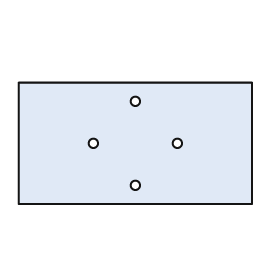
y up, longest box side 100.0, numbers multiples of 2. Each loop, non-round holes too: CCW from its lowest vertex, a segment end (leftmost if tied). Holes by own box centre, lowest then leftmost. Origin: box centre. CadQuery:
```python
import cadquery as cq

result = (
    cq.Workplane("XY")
    .moveTo(-50.0, -26.0)
    .lineTo(50.0, -26.0)
    .lineTo(50.0, 26.0)
    .lineTo(-50.0, 26.0)
    .close()
    .moveTo(0.0, -18.0)
    .circle(2.0)
    .moveTo(-18.0, 0.0)
    .circle(2.0)
    .moveTo(18.0, 0.0)
    .circle(2.0)
    .moveTo(0.0, 18.0)
    .circle(2.0)
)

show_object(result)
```